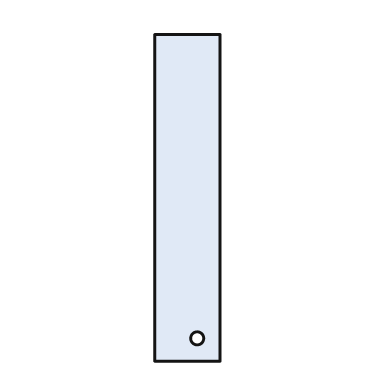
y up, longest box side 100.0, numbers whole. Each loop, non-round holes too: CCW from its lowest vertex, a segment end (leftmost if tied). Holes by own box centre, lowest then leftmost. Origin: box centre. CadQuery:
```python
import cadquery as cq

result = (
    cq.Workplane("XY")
    .moveTo(-10.0, -50.0)
    .lineTo(10.0, -50.0)
    .lineTo(10.0, 50.0)
    .lineTo(-10.0, 50.0)
    .close()
    .moveTo(3.0, -43.0)
    .circle(2.0)
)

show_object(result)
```